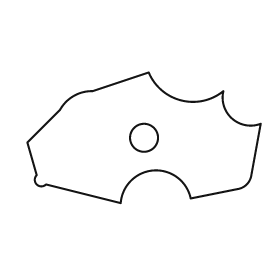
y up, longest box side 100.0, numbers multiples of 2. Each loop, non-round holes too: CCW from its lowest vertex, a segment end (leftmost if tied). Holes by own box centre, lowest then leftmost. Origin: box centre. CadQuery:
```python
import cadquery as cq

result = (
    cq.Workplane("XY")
    .moveTo(-10.0, -28.0)
    .threePointArc((4.0, -14.0), (20.0, -26.0))
    .lineTo(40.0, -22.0)
    .threePointArc((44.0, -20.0), (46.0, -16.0))
    .lineTo(50.0, 6.0)
    .threePointArc((38.0, 8.0), (34.0, 20.0))
    .threePointArc((16.0, 16.0), (2.0, 28.0))
    .lineTo(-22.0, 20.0)
    .threePointArc((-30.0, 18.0), (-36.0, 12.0))
    .lineTo(-50.0, -2.0)
    .lineTo(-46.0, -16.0)
    .threePointArc((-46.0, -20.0), (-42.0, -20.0))
    .close()
    .moveTo(0.0, 0.0)
    .circle(6.0)
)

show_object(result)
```